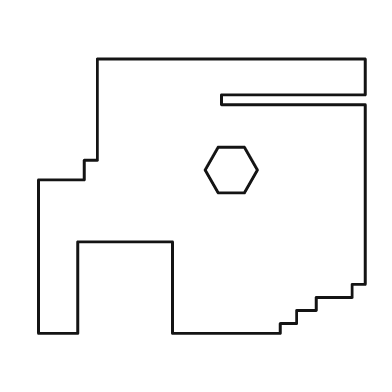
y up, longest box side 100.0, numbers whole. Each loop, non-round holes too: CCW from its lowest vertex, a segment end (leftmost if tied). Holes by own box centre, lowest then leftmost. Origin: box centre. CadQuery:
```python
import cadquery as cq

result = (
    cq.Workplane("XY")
    .moveTo(-50.0, -42.0)
    .lineTo(-38.0, -42.0)
    .lineTo(-38.0, -14.0)
    .lineTo(-9.0, -14.0)
    .lineTo(-9.0, -42.0)
    .lineTo(24.0, -42.0)
    .lineTo(24.0, -39.0)
    .lineTo(29.0, -39.0)
    .lineTo(29.0, -35.0)
    .lineTo(35.0, -35.0)
    .lineTo(35.0, -31.0)
    .lineTo(46.0, -31.0)
    .lineTo(46.0, -27.0)
    .lineTo(50.0, -27.0)
    .lineTo(50.0, 28.0)
    .lineTo(6.0, 28.0)
    .lineTo(6.0, 31.0)
    .lineTo(50.0, 31.0)
    .lineTo(50.0, 42.0)
    .lineTo(-32.0, 42.0)
    .lineTo(-32.0, 11.0)
    .lineTo(-36.0, 11.0)
    .lineTo(-36.0, 5.0)
    .lineTo(-50.0, 5.0)
    .close()
    .moveTo(5.0, 1.0)
    .lineTo(13.0, 1.0)
    .lineTo(17.0, 8.0)
    .lineTo(13.0, 15.0)
    .lineTo(5.0, 15.0)
    .lineTo(1.0, 8.0)
    .close()
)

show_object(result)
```